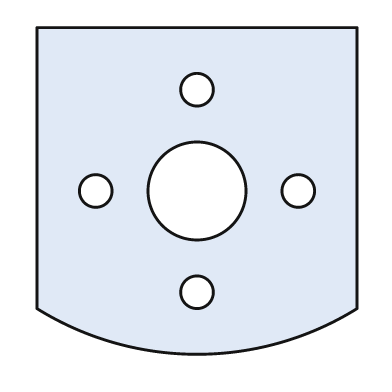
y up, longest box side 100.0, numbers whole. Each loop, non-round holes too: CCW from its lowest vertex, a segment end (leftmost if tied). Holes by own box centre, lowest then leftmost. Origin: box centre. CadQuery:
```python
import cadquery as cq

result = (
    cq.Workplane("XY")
    .moveTo(-49.0, -36.0)
    .threePointArc((0.0, -50.0), (49.0, -36.0))
    .lineTo(49.0, 50.0)
    .lineTo(-49.0, 50.0)
    .close()
    .moveTo(0.0, -31.0)
    .circle(5.0)
    .moveTo(-31.0, 0.0)
    .circle(5.0)
    .moveTo(0.0, 0.0)
    .circle(15.0)
    .moveTo(31.0, 0.0)
    .circle(5.0)
    .moveTo(0.0, 31.0)
    .circle(5.0)
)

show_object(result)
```